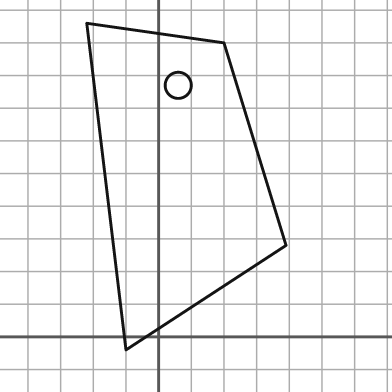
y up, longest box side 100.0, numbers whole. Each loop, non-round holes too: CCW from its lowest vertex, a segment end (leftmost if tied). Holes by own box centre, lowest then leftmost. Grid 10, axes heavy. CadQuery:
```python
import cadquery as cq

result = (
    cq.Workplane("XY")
    .moveTo(-10.0, -4.0)
    .lineTo(39.0, 28.0)
    .lineTo(20.0, 90.0)
    .lineTo(-22.0, 96.0)
    .close()
    .moveTo(6.0, 77.0)
    .circle(4.0)
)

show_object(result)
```